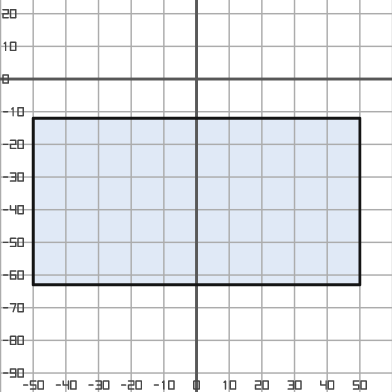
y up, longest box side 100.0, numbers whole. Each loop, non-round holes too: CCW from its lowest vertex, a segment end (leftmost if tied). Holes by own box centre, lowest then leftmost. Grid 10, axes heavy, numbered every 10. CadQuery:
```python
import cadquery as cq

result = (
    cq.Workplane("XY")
    .moveTo(-50.0, -63.0)
    .lineTo(50.0, -63.0)
    .lineTo(50.0, -12.0)
    .lineTo(-50.0, -12.0)
    .close()
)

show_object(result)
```